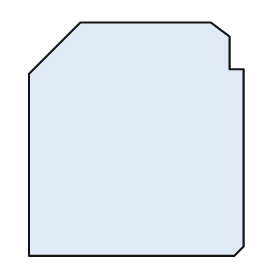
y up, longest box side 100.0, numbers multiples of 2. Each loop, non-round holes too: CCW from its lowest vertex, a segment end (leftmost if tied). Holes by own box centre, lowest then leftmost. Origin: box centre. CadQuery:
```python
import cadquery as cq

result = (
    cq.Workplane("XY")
    .moveTo(-46.0, -50.0)
    .lineTo(42.0, -50.0)
    .lineTo(46.0, -46.0)
    .lineTo(46.0, 30.0)
    .lineTo(40.0, 30.0)
    .lineTo(40.0, 44.0)
    .lineTo(32.0, 50.0)
    .lineTo(-24.0, 50.0)
    .lineTo(-46.0, 28.0)
    .close()
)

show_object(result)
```